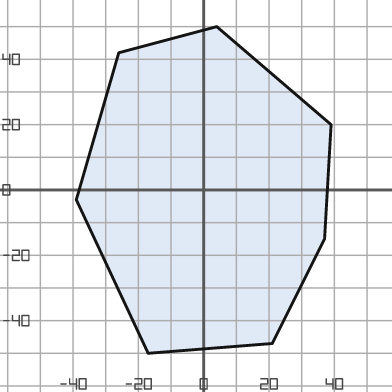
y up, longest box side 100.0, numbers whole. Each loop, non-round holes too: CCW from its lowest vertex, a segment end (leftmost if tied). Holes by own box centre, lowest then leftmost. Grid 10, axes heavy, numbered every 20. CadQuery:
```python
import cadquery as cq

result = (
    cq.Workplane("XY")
    .moveTo(-17.0, -50.0)
    .lineTo(21.0, -47.0)
    .lineTo(37.0, -15.0)
    .lineTo(39.0, 20.0)
    .lineTo(4.0, 50.0)
    .lineTo(-26.0, 42.0)
    .lineTo(-39.0, -3.0)
    .close()
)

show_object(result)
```